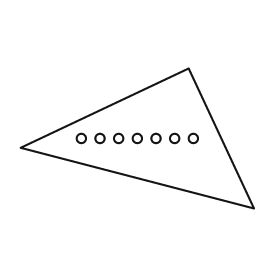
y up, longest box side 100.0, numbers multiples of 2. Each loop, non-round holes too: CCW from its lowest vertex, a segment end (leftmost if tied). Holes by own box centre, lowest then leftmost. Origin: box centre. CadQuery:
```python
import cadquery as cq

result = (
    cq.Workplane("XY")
    .moveTo(50.0, -30.0)
    .lineTo(22.0, 30.0)
    .lineTo(-50.0, -4.0)
    .close()
    .moveTo(-24.0, 0.0)
    .circle(2.0)
    .moveTo(-16.0, 0.0)
    .circle(2.0)
    .moveTo(-8.0, 0.0)
    .circle(2.0)
    .moveTo(0.0, 0.0)
    .circle(2.0)
    .moveTo(8.0, 0.0)
    .circle(2.0)
    .moveTo(16.0, 0.0)
    .circle(2.0)
    .moveTo(24.0, 0.0)
    .circle(2.0)
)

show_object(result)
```